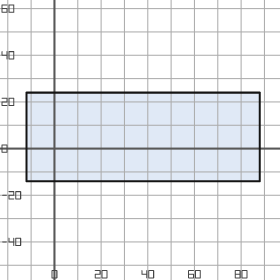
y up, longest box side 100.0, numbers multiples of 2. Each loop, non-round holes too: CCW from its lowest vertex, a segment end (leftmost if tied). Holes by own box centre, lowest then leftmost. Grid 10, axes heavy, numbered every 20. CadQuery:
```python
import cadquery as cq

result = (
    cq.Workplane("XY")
    .moveTo(-12.0, -14.0)
    .lineTo(88.0, -14.0)
    .lineTo(88.0, 24.0)
    .lineTo(-12.0, 24.0)
    .close()
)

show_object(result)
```